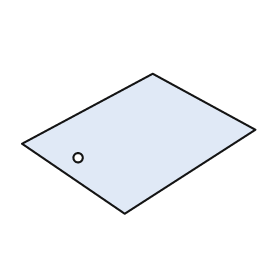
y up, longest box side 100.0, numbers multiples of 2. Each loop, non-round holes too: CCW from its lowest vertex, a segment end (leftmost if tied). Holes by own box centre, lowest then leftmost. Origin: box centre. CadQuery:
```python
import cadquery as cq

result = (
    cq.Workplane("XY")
    .moveTo(-6.0, -30.0)
    .lineTo(50.0, 6.0)
    .lineTo(6.0, 30.0)
    .lineTo(-50.0, 0.0)
    .close()
    .moveTo(-26.0, -6.0)
    .circle(2.0)
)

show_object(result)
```